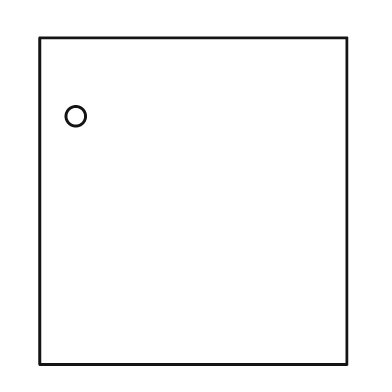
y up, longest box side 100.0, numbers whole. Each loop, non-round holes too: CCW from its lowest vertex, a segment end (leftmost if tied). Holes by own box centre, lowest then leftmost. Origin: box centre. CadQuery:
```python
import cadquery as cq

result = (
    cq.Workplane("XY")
    .moveTo(-47.0, -50.0)
    .lineTo(47.0, -50.0)
    .lineTo(47.0, 50.0)
    .lineTo(-47.0, 50.0)
    .close()
    .moveTo(-36.0, 26.0)
    .circle(3.0)
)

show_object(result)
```